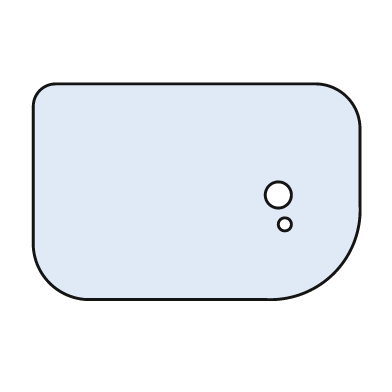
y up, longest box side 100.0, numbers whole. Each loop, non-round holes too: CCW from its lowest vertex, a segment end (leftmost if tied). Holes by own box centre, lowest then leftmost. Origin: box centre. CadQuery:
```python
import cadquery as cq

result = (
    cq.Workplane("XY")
    .moveTo(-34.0, -33.0)
    .lineTo(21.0, -33.0)
    .threePointArc((42.0, -25.0), (50.0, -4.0))
    .lineTo(50.0, 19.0)
    .threePointArc((46.0, 29.0), (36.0, 33.0))
    .lineTo(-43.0, 33.0)
    .threePointArc((-48.0, 31.0), (-50.0, 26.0))
    .lineTo(-50.0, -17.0)
    .threePointArc((-45.0, -28.0), (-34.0, -33.0))
    .close()
    .moveTo(27.0, -10.0)
    .circle(2.0)
    .moveTo(25.0, -1.0)
    .circle(4.0)
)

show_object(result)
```